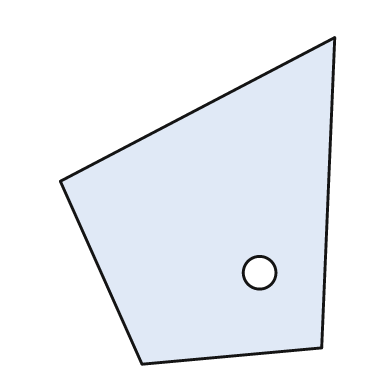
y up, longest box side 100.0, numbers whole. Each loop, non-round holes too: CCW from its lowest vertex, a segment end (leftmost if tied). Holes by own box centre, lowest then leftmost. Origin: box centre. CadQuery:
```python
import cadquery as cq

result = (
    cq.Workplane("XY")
    .moveTo(-17.0, -50.0)
    .lineTo(38.0, -45.0)
    .lineTo(42.0, 50.0)
    .lineTo(-42.0, 6.0)
    .close()
    .moveTo(19.0, -22.0)
    .circle(5.0)
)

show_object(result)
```